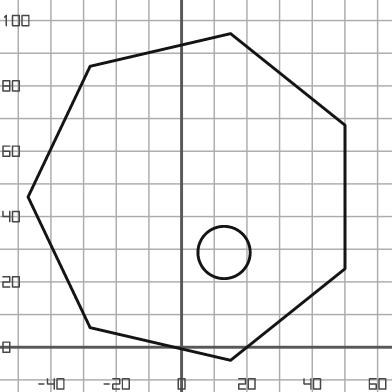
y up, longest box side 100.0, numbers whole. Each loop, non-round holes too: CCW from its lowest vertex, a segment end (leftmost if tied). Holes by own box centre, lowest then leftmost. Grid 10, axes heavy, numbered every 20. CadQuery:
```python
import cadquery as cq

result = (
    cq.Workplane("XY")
    .moveTo(15.0, -4.0)
    .lineTo(50.0, 24.0)
    .lineTo(50.0, 68.0)
    .lineTo(15.0, 96.0)
    .lineTo(-28.0, 86.0)
    .lineTo(-47.0, 46.0)
    .lineTo(-28.0, 6.0)
    .close()
    .moveTo(13.0, 29.0)
    .circle(8.0)
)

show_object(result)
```